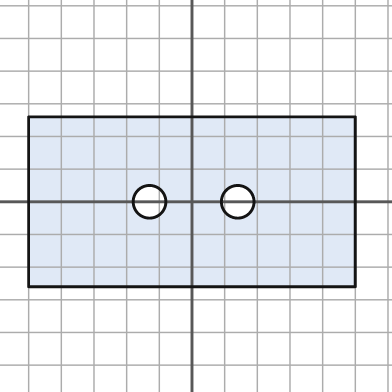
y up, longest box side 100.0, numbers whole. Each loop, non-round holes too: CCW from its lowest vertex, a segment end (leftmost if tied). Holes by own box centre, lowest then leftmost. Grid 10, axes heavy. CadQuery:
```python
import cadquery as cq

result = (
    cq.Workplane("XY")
    .moveTo(-50.0, -26.0)
    .lineTo(50.0, -26.0)
    .lineTo(50.0, 26.0)
    .lineTo(-50.0, 26.0)
    .close()
    .moveTo(-13.0, 0.0)
    .circle(5.0)
    .moveTo(14.0, 0.0)
    .circle(5.0)
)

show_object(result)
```